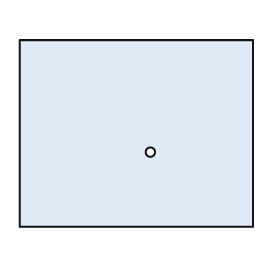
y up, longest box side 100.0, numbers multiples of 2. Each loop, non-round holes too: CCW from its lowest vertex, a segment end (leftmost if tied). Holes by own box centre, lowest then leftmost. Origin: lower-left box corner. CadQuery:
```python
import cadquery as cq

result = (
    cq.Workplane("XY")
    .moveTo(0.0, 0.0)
    .lineTo(100.0, 0.0)
    .lineTo(100.0, 80.0)
    .lineTo(0.0, 80.0)
    .close()
    .moveTo(56.0, 32.0)
    .circle(2.0)
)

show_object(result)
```